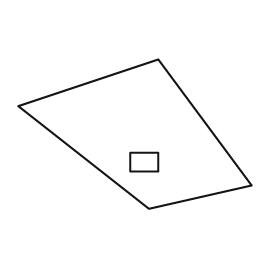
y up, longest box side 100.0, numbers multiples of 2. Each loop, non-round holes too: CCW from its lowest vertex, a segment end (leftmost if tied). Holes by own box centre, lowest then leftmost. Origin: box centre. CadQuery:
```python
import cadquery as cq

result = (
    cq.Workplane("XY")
    .moveTo(6.0, -32.0)
    .lineTo(50.0, -22.0)
    .lineTo(10.0, 32.0)
    .lineTo(-50.0, 12.0)
    .close()
    .moveTo(-2.0, -16.0)
    .lineTo(10.0, -16.0)
    .lineTo(10.0, -8.0)
    .lineTo(-2.0, -8.0)
    .close()
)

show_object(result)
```